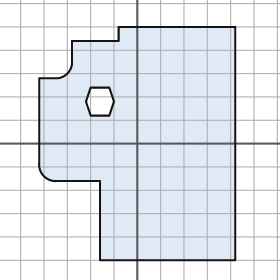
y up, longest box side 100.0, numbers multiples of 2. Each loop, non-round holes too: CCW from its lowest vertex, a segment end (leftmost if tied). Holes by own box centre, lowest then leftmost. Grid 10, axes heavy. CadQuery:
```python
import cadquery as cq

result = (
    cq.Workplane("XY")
    .moveTo(-16.0, -50.0)
    .lineTo(42.0, -50.0)
    .lineTo(42.0, 50.0)
    .lineTo(-8.0, 50.0)
    .lineTo(-8.0, 44.0)
    .lineTo(-28.0, 44.0)
    .lineTo(-28.0, 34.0)
    .threePointArc((-30.0, 30.0), (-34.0, 28.0))
    .lineTo(-42.0, 28.0)
    .lineTo(-42.0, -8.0)
    .threePointArc((-40.0, -14.0), (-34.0, -16.0))
    .lineTo(-16.0, -16.0)
    .close()
    .moveTo(-20.0, 12.0)
    .lineTo(-12.0, 12.0)
    .lineTo(-10.0, 18.0)
    .lineTo(-12.0, 24.0)
    .lineTo(-20.0, 24.0)
    .lineTo(-22.0, 18.0)
    .close()
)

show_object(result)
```